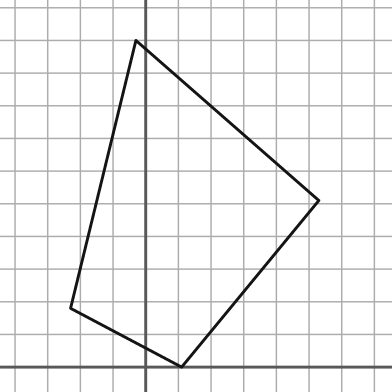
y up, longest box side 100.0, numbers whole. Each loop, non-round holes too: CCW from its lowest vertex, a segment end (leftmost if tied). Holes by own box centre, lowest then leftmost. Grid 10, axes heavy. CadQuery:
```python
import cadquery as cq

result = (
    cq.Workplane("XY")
    .moveTo(11.0, 0.0)
    .lineTo(53.0, 51.0)
    .lineTo(-3.0, 100.0)
    .lineTo(-23.0, 18.0)
    .close()
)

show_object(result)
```